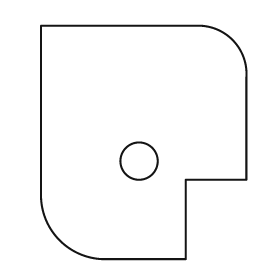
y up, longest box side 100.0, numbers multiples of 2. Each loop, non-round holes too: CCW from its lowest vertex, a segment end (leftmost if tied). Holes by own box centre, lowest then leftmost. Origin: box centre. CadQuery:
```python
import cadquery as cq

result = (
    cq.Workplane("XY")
    .moveTo(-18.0, -50.0)
    .lineTo(18.0, -50.0)
    .lineTo(18.0, -16.0)
    .lineTo(44.0, -16.0)
    .lineTo(44.0, 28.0)
    .threePointArc((38.0, 44.0), (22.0, 50.0))
    .lineTo(-44.0, 50.0)
    .lineTo(-44.0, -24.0)
    .threePointArc((-36.0, -42.0), (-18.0, -50.0))
    .close()
    .moveTo(-2.0, -8.0)
    .circle(8.0)
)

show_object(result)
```